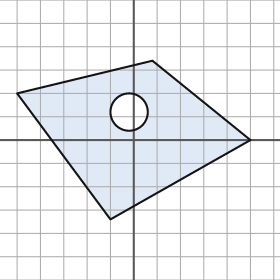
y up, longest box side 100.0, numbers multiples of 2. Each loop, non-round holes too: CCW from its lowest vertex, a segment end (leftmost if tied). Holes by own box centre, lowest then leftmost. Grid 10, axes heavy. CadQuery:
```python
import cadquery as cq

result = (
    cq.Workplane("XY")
    .moveTo(-10.0, -34.0)
    .lineTo(50.0, 0.0)
    .lineTo(8.0, 34.0)
    .lineTo(-50.0, 20.0)
    .close()
    .moveTo(-2.0, 12.0)
    .circle(8.0)
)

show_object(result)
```